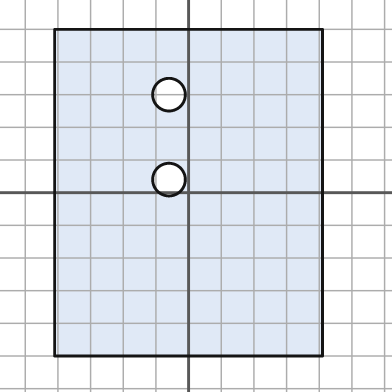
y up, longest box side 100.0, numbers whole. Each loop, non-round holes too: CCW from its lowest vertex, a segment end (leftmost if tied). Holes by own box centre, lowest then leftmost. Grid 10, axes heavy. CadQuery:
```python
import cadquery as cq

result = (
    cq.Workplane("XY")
    .moveTo(-41.0, -50.0)
    .lineTo(41.0, -50.0)
    .lineTo(41.0, 50.0)
    .lineTo(-41.0, 50.0)
    .close()
    .moveTo(-6.0, 4.0)
    .circle(5.0)
    .moveTo(-6.0, 30.0)
    .circle(5.0)
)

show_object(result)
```